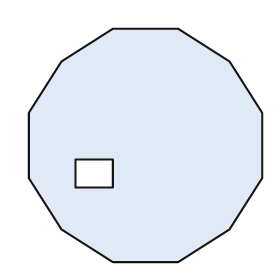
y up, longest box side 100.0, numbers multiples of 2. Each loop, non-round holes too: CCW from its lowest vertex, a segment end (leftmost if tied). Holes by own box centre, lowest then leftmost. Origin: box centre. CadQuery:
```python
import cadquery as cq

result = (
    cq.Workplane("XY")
    .moveTo(-14.0, -50.0)
    .lineTo(14.0, -50.0)
    .lineTo(36.0, -36.0)
    .lineTo(50.0, -14.0)
    .lineTo(50.0, 14.0)
    .lineTo(36.0, 36.0)
    .lineTo(14.0, 50.0)
    .lineTo(-14.0, 50.0)
    .lineTo(-36.0, 36.0)
    .lineTo(-50.0, 14.0)
    .lineTo(-50.0, -14.0)
    .lineTo(-36.0, -36.0)
    .close()
    .moveTo(-30.0, -18.0)
    .lineTo(-14.0, -18.0)
    .lineTo(-14.0, -6.0)
    .lineTo(-30.0, -6.0)
    .close()
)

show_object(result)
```